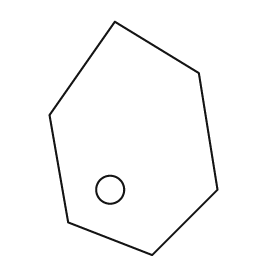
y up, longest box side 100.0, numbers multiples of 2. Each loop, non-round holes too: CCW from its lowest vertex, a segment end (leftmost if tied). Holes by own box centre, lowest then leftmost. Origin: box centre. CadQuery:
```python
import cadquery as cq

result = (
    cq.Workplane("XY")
    .moveTo(8.0, -50.0)
    .lineTo(36.0, -22.0)
    .lineTo(28.0, 28.0)
    .lineTo(-8.0, 50.0)
    .lineTo(-36.0, 10.0)
    .lineTo(-28.0, -36.0)
    .close()
    .moveTo(-10.0, -22.0)
    .circle(6.0)
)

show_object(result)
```